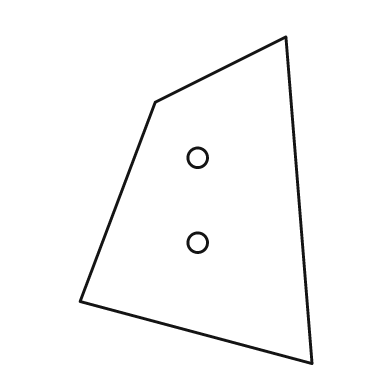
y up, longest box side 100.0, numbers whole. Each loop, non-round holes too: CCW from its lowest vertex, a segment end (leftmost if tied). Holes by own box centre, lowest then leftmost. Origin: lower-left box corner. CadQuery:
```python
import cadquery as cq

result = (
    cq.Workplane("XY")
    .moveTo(71.0, 0.0)
    .lineTo(63.0, 100.0)
    .lineTo(23.0, 80.0)
    .lineTo(0.0, 19.0)
    .close()
    .moveTo(36.0, 37.0)
    .circle(3.0)
    .moveTo(36.0, 63.0)
    .circle(3.0)
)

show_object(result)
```